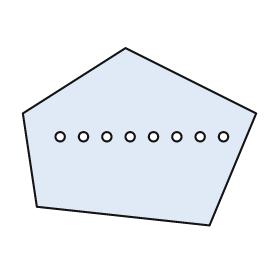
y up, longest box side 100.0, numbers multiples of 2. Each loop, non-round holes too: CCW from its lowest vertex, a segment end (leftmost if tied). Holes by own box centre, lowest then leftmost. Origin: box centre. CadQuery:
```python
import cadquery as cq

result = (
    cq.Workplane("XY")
    .moveTo(30.0, -38.0)
    .lineTo(50.0, 10.0)
    .lineTo(-6.0, 38.0)
    .lineTo(-50.0, 10.0)
    .lineTo(-44.0, -30.0)
    .close()
    .moveTo(-34.0, 0.0)
    .circle(2.0)
    .moveTo(-24.0, 0.0)
    .circle(2.0)
    .moveTo(-14.0, 0.0)
    .circle(2.0)
    .moveTo(-4.0, 0.0)
    .circle(2.0)
    .moveTo(6.0, 0.0)
    .circle(2.0)
    .moveTo(16.0, 0.0)
    .circle(2.0)
    .moveTo(26.0, 0.0)
    .circle(2.0)
    .moveTo(36.0, 0.0)
    .circle(2.0)
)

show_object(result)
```